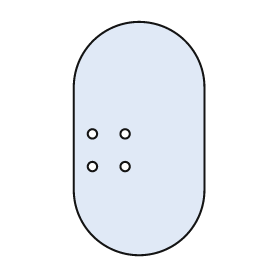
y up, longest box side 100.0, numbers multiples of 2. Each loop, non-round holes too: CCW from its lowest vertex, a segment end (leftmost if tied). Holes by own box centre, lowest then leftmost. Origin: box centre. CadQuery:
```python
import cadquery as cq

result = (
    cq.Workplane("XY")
    .moveTo(-28.0, -22.0)
    .threePointArc((0.0, -50.0), (28.0, -22.0))
    .lineTo(28.0, 22.0)
    .threePointArc((0.0, 50.0), (-28.0, 22.0))
    .close()
    .moveTo(-20.0, -12.0)
    .circle(2.0)
    .moveTo(-6.0, -12.0)
    .circle(2.0)
    .moveTo(-20.0, 2.0)
    .circle(2.0)
    .moveTo(-6.0, 2.0)
    .circle(2.0)
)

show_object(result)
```